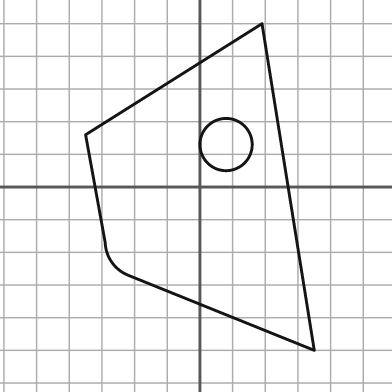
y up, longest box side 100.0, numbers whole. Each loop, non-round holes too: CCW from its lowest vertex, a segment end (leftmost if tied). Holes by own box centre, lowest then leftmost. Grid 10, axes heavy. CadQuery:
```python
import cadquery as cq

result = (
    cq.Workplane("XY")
    .moveTo(35.0, -50.0)
    .lineTo(19.0, 50.0)
    .lineTo(-35.0, 16.0)
    .lineTo(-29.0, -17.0)
    .threePointArc((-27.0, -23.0), (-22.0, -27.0))
    .close()
    .moveTo(8.0, 13.0)
    .circle(8.0)
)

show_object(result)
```